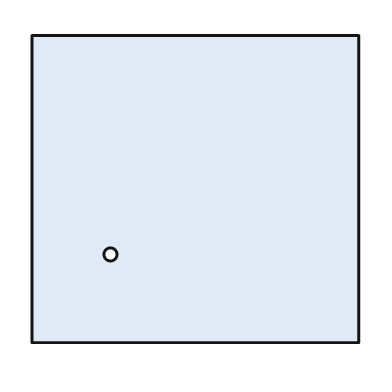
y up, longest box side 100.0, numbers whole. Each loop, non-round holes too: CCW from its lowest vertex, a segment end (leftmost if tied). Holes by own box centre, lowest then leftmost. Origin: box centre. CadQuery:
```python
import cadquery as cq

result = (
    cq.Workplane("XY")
    .moveTo(-50.0, -47.0)
    .lineTo(50.0, -47.0)
    .lineTo(50.0, 47.0)
    .lineTo(-50.0, 47.0)
    .close()
    .moveTo(-26.0, -20.0)
    .circle(2.0)
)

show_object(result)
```